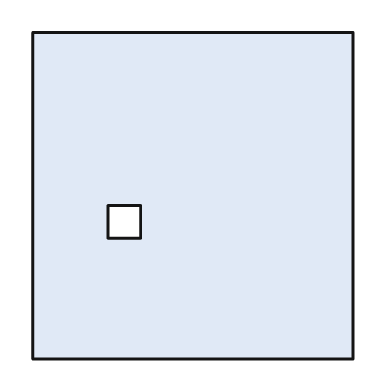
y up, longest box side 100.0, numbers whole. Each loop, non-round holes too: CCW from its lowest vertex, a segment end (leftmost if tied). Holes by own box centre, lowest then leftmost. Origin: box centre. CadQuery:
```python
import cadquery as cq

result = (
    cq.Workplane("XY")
    .moveTo(-49.0, -50.0)
    .lineTo(49.0, -50.0)
    .lineTo(49.0, 50.0)
    .lineTo(-49.0, 50.0)
    .close()
    .moveTo(-26.0, -13.0)
    .lineTo(-16.0, -13.0)
    .lineTo(-16.0, -3.0)
    .lineTo(-26.0, -3.0)
    .close()
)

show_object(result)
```